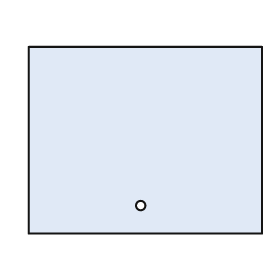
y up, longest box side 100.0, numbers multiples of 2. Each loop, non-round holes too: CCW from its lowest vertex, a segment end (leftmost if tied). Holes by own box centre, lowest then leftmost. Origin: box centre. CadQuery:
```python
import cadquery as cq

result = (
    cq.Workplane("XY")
    .moveTo(-50.0, -40.0)
    .lineTo(50.0, -40.0)
    .lineTo(50.0, 40.0)
    .lineTo(-50.0, 40.0)
    .close()
    .moveTo(-2.0, -28.0)
    .circle(2.0)
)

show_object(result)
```